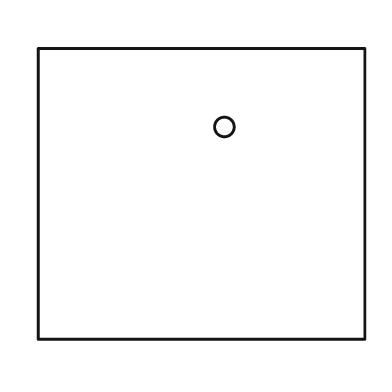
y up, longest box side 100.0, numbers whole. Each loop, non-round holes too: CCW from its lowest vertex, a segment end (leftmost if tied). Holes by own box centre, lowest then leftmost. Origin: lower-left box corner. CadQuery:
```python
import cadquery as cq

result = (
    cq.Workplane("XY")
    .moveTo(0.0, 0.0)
    .lineTo(100.0, 0.0)
    .lineTo(100.0, 89.0)
    .lineTo(0.0, 89.0)
    .close()
    .moveTo(57.0, 65.0)
    .circle(3.0)
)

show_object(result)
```